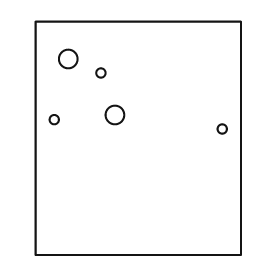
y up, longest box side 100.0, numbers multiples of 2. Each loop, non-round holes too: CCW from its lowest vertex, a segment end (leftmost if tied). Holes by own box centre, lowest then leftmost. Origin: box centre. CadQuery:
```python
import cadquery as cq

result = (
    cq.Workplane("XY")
    .moveTo(-44.0, -50.0)
    .lineTo(44.0, -50.0)
    .lineTo(44.0, 50.0)
    .lineTo(-44.0, 50.0)
    .close()
    .moveTo(36.0, 4.0)
    .circle(2.0)
    .moveTo(-36.0, 8.0)
    .circle(2.0)
    .moveTo(-10.0, 10.0)
    .circle(4.0)
    .moveTo(-16.0, 28.0)
    .circle(2.0)
    .moveTo(-30.0, 34.0)
    .circle(4.0)
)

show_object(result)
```